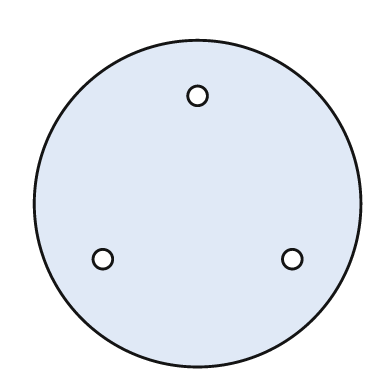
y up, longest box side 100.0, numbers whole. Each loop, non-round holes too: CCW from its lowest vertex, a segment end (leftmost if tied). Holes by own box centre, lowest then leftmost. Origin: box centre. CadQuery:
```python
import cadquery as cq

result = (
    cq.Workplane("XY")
    .moveTo(0.0, 0.0)
    .circle(50.0)
    .moveTo(-29.0, -17.0)
    .circle(3.0)
    .moveTo(29.0, -17.0)
    .circle(3.0)
    .moveTo(0.0, 33.0)
    .circle(3.0)
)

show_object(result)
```